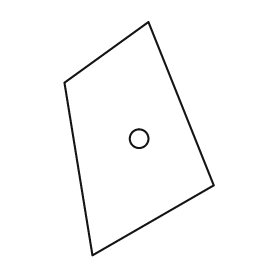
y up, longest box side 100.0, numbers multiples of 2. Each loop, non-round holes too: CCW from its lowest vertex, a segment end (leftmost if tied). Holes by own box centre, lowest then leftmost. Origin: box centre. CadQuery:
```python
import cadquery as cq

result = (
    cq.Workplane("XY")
    .moveTo(-20.0, -50.0)
    .lineTo(32.0, -20.0)
    .lineTo(4.0, 50.0)
    .lineTo(-32.0, 24.0)
    .close()
    .moveTo(0.0, 0.0)
    .circle(4.0)
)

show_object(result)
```